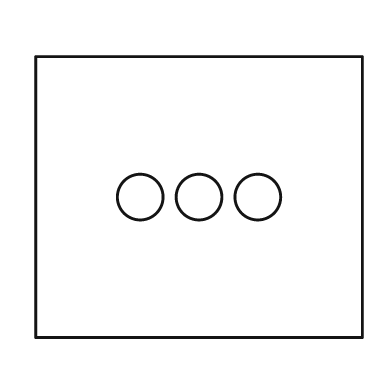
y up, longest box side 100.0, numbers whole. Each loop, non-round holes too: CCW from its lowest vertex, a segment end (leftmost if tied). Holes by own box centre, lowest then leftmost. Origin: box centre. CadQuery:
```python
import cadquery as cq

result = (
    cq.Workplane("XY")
    .moveTo(-50.0, -43.0)
    .lineTo(50.0, -43.0)
    .lineTo(50.0, 43.0)
    .lineTo(-50.0, 43.0)
    .close()
    .moveTo(-18.0, 0.0)
    .circle(7.0)
    .moveTo(0.0, 0.0)
    .circle(7.0)
    .moveTo(18.0, 0.0)
    .circle(7.0)
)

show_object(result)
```